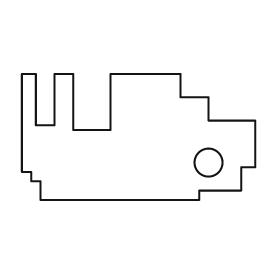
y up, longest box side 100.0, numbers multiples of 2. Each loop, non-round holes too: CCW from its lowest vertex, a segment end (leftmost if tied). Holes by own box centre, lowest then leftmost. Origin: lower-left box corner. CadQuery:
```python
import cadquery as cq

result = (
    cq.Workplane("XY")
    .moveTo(8.0, 0.0)
    .lineTo(76.0, 0.0)
    .lineTo(76.0, 4.0)
    .lineTo(94.0, 4.0)
    .lineTo(94.0, 14.0)
    .lineTo(100.0, 14.0)
    .lineTo(100.0, 34.0)
    .lineTo(80.0, 34.0)
    .lineTo(80.0, 44.0)
    .lineTo(68.0, 44.0)
    .lineTo(68.0, 54.0)
    .lineTo(38.0, 54.0)
    .lineTo(38.0, 30.0)
    .lineTo(22.0, 30.0)
    .lineTo(22.0, 54.0)
    .lineTo(14.0, 54.0)
    .lineTo(14.0, 32.0)
    .lineTo(6.0, 32.0)
    .lineTo(6.0, 54.0)
    .lineTo(0.0, 54.0)
    .lineTo(0.0, 12.0)
    .lineTo(4.0, 12.0)
    .lineTo(4.0, 8.0)
    .lineTo(8.0, 8.0)
    .close()
    .moveTo(80.0, 16.0)
    .circle(6.0)
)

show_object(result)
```